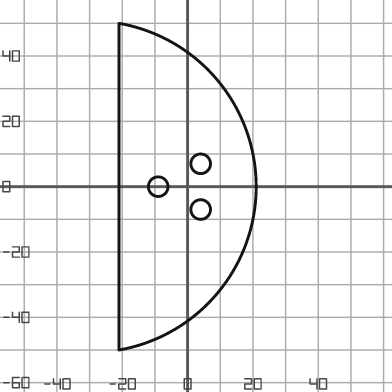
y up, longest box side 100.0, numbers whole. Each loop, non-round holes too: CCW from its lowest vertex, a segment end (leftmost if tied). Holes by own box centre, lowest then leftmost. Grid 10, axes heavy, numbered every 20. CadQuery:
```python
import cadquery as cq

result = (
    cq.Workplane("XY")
    .moveTo(-21.0, -50.0)
    .threePointArc((21.0, 0.0), (-21.0, 50.0))
    .close()
    .moveTo(4.0, -7.0)
    .circle(3.0)
    .moveTo(-9.0, 0.0)
    .circle(3.0)
    .moveTo(4.0, 7.0)
    .circle(3.0)
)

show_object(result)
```